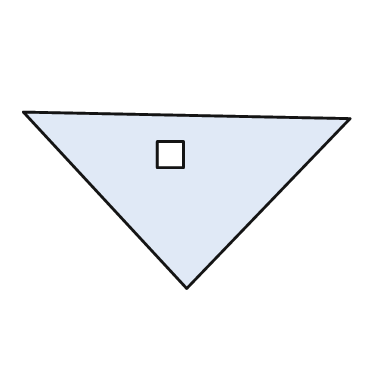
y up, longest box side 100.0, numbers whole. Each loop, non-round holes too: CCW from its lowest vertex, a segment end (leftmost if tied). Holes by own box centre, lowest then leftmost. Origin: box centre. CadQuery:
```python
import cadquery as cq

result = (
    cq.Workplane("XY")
    .moveTo(0.0, -27.0)
    .lineTo(50.0, 25.0)
    .lineTo(-50.0, 27.0)
    .close()
    .moveTo(-9.0, 10.0)
    .lineTo(-1.0, 10.0)
    .lineTo(-1.0, 18.0)
    .lineTo(-9.0, 18.0)
    .close()
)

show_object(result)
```